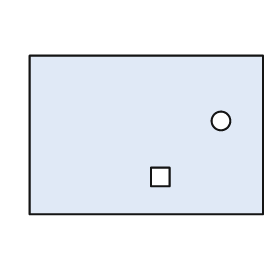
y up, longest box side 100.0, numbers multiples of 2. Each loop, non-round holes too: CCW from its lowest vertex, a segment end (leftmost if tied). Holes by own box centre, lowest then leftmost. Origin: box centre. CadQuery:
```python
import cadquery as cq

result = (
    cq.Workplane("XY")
    .moveTo(-50.0, -34.0)
    .lineTo(50.0, -34.0)
    .lineTo(50.0, 34.0)
    .lineTo(-50.0, 34.0)
    .close()
    .moveTo(2.0, -22.0)
    .lineTo(10.0, -22.0)
    .lineTo(10.0, -14.0)
    .lineTo(2.0, -14.0)
    .close()
    .moveTo(32.0, 6.0)
    .circle(4.0)
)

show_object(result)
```